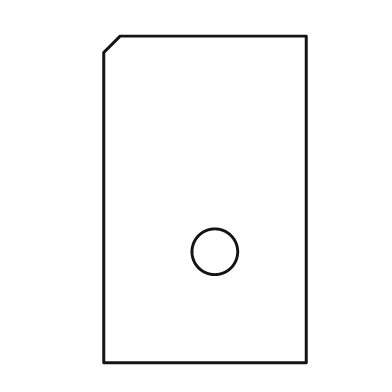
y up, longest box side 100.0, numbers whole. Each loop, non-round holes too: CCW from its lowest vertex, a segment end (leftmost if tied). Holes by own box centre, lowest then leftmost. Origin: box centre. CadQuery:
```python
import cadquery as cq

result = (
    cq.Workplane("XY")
    .moveTo(-31.0, -50.0)
    .lineTo(31.0, -50.0)
    .lineTo(31.0, 50.0)
    .lineTo(-26.0, 50.0)
    .lineTo(-31.0, 45.0)
    .close()
    .moveTo(3.0, -16.0)
    .circle(7.0)
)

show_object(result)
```